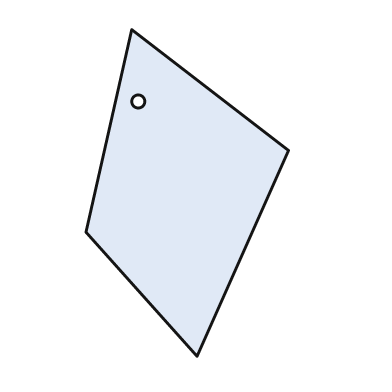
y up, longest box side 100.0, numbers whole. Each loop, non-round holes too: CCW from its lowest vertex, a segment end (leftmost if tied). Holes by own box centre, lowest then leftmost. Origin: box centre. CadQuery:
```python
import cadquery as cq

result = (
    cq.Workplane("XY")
    .moveTo(3.0, -50.0)
    .lineTo(31.0, 13.0)
    .lineTo(-17.0, 50.0)
    .lineTo(-31.0, -12.0)
    .close()
    .moveTo(-15.0, 28.0)
    .circle(2.0)
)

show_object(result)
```